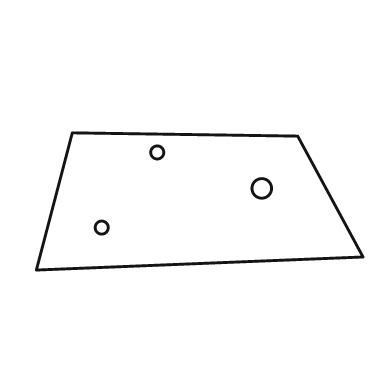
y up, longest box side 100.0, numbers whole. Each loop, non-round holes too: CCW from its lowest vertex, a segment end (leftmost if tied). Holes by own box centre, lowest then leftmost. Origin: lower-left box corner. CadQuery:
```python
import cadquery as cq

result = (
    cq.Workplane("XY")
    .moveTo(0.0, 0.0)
    .lineTo(100.0, 4.0)
    .lineTo(80.0, 41.0)
    .lineTo(11.0, 42.0)
    .close()
    .moveTo(20.0, 13.0)
    .circle(2.0)
    .moveTo(69.0, 25.0)
    .circle(3.0)
    .moveTo(37.0, 36.0)
    .circle(2.0)
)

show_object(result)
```